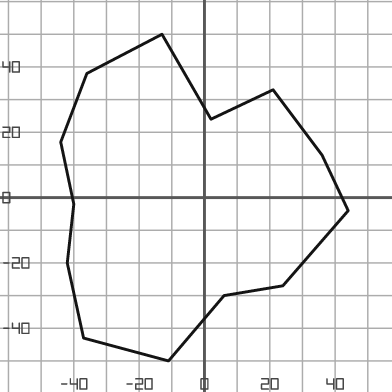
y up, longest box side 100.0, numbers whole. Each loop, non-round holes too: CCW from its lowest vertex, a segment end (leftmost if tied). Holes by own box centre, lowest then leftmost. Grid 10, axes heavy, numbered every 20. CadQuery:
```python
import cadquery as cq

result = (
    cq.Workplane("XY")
    .moveTo(-11.0, -50.0)
    .lineTo(6.0, -30.0)
    .lineTo(24.0, -27.0)
    .lineTo(44.0, -4.0)
    .lineTo(36.0, 13.0)
    .lineTo(21.0, 33.0)
    .lineTo(2.0, 24.0)
    .lineTo(-13.0, 50.0)
    .lineTo(-36.0, 38.0)
    .lineTo(-44.0, 17.0)
    .lineTo(-40.0, -2.0)
    .lineTo(-42.0, -20.0)
    .lineTo(-37.0, -43.0)
    .close()
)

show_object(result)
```